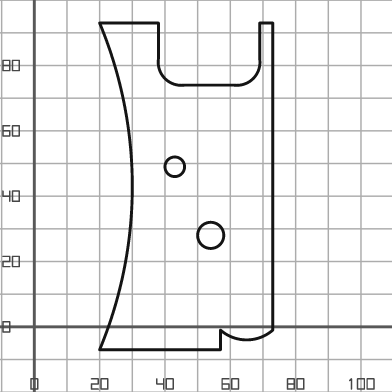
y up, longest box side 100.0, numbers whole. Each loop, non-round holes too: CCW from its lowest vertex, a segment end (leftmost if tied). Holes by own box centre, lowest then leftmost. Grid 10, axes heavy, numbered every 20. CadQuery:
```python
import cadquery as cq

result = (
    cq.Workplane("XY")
    .moveTo(20.0, -7.0)
    .lineTo(57.0, -7.0)
    .lineTo(57.0, -1.0)
    .threePointArc((65.0, -4.0), (73.0, -1.0))
    .lineTo(73.0, 93.0)
    .lineTo(69.0, 93.0)
    .lineTo(69.0, 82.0)
    .threePointArc((67.0, 76.0), (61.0, 74.0))
    .lineTo(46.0, 74.0)
    .threePointArc((40.0, 76.0), (38.0, 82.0))
    .lineTo(38.0, 93.0)
    .lineTo(20.0, 93.0)
    .threePointArc((30.0, 43.0), (20.0, -7.0))
    .close()
    .moveTo(54.0, 28.0)
    .circle(4.0)
    .moveTo(43.0, 49.0)
    .circle(3.0)
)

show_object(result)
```